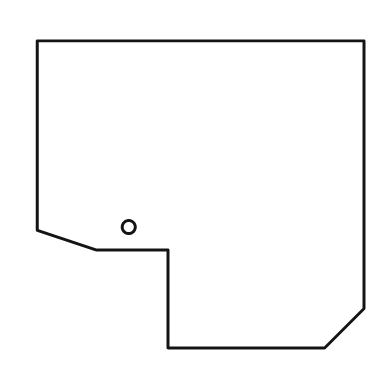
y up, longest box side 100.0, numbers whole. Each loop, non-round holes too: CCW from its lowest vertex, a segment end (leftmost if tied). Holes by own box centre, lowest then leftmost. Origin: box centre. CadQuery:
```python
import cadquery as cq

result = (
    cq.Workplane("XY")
    .moveTo(-10.0, -47.0)
    .lineTo(38.0, -47.0)
    .lineTo(50.0, -35.0)
    .lineTo(50.0, 47.0)
    .lineTo(-50.0, 47.0)
    .lineTo(-50.0, -11.0)
    .lineTo(-32.0, -17.0)
    .lineTo(-10.0, -17.0)
    .close()
    .moveTo(-22.0, -10.0)
    .circle(2.0)
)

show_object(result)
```